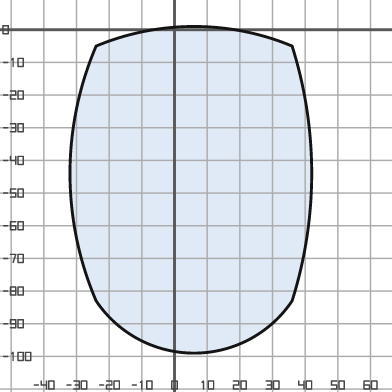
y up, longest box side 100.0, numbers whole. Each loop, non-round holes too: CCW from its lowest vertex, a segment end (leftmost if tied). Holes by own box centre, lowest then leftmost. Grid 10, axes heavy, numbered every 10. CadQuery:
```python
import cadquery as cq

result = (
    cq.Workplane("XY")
    .moveTo(-24.0, -83.0)
    .threePointArc((6.0, -99.0), (36.0, -83.0))
    .threePointArc((42.0, -44.0), (36.0, -5.0))
    .threePointArc((6.0, 1.0), (-24.0, -5.0))
    .threePointArc((-32.0, -44.0), (-24.0, -83.0))
    .close()
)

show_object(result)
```